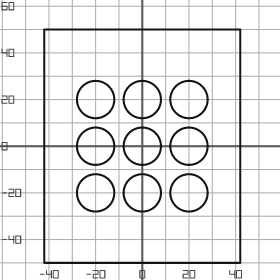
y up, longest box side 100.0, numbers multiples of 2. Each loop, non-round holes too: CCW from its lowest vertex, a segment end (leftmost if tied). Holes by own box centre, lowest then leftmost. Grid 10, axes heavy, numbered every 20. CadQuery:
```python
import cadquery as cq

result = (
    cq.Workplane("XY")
    .moveTo(-42.0, -50.0)
    .lineTo(42.0, -50.0)
    .lineTo(42.0, 50.0)
    .lineTo(-42.0, 50.0)
    .close()
    .moveTo(-20.0, -20.0)
    .circle(8.0)
    .moveTo(0.0, -20.0)
    .circle(8.0)
    .moveTo(20.0, -20.0)
    .circle(8.0)
    .moveTo(-20.0, 0.0)
    .circle(8.0)
    .moveTo(0.0, 0.0)
    .circle(8.0)
    .moveTo(20.0, 0.0)
    .circle(8.0)
    .moveTo(-20.0, 20.0)
    .circle(8.0)
    .moveTo(0.0, 20.0)
    .circle(8.0)
    .moveTo(20.0, 20.0)
    .circle(8.0)
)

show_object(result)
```